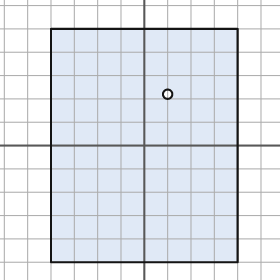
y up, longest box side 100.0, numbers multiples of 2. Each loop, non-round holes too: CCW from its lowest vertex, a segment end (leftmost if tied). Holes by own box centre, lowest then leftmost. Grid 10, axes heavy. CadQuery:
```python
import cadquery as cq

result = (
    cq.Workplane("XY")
    .moveTo(-40.0, -50.0)
    .lineTo(40.0, -50.0)
    .lineTo(40.0, 50.0)
    .lineTo(-40.0, 50.0)
    .close()
    .moveTo(10.0, 22.0)
    .circle(2.0)
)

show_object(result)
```